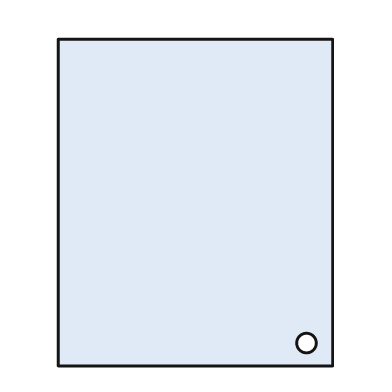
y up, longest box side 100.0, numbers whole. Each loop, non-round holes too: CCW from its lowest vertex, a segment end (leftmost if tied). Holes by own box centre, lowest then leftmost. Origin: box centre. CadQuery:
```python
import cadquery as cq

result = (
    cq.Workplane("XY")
    .moveTo(-42.0, -50.0)
    .lineTo(42.0, -50.0)
    .lineTo(42.0, 50.0)
    .lineTo(-42.0, 50.0)
    .close()
    .moveTo(34.0, -43.0)
    .circle(3.0)
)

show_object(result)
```